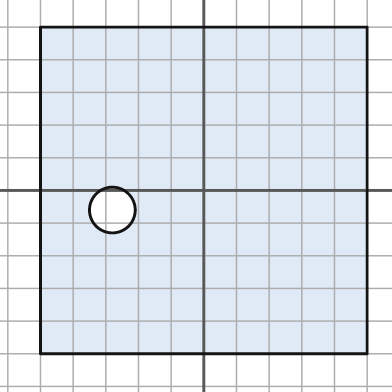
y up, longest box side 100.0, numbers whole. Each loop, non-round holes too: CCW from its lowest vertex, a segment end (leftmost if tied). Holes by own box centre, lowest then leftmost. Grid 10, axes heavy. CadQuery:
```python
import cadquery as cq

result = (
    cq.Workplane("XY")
    .moveTo(-50.0, -50.0)
    .lineTo(50.0, -50.0)
    .lineTo(50.0, 50.0)
    .lineTo(-50.0, 50.0)
    .close()
    .moveTo(-28.0, -6.0)
    .circle(7.0)
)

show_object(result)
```